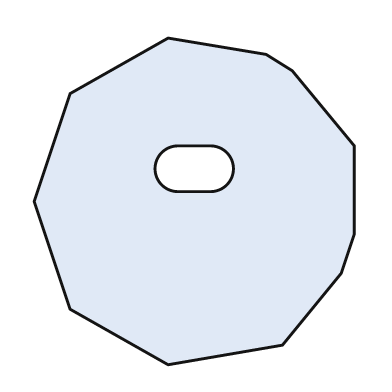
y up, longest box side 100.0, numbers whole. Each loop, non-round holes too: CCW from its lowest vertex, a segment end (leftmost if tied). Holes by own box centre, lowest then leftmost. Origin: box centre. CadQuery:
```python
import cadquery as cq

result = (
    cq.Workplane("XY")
    .moveTo(-8.0, -50.0)
    .lineTo(27.0, -44.0)
    .lineTo(45.0, -22.0)
    .lineTo(49.0, -10.0)
    .lineTo(49.0, 17.0)
    .lineTo(30.0, 40.0)
    .lineTo(22.0, 45.0)
    .lineTo(-8.0, 50.0)
    .lineTo(-38.0, 33.0)
    .lineTo(-49.0, 0.0)
    .lineTo(-38.0, -33.0)
    .close()
    .moveTo(-5.0, 3.0)
    .lineTo(5.0, 3.0)
    .threePointArc((12.0, 10.0), (5.0, 17.0))
    .lineTo(-5.0, 17.0)
    .threePointArc((-12.0, 10.0), (-5.0, 3.0))
    .close()
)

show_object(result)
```